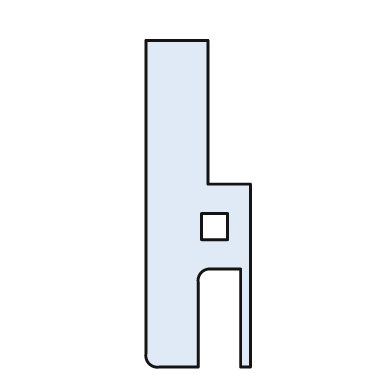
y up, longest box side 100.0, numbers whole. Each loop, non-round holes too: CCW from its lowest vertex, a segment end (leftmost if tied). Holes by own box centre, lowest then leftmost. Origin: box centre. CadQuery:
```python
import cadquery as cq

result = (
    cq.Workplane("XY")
    .moveTo(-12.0, -50.0)
    .lineTo(0.0, -50.0)
    .lineTo(0.0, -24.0)
    .threePointArc((1.0, -21.0), (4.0, -20.0))
    .lineTo(13.0, -20.0)
    .lineTo(13.0, -50.0)
    .lineTo(16.0, -50.0)
    .lineTo(16.0, 6.0)
    .lineTo(3.0, 6.0)
    .lineTo(3.0, 50.0)
    .lineTo(-16.0, 50.0)
    .lineTo(-16.0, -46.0)
    .threePointArc((-15.0, -49.0), (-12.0, -50.0))
    .close()
    .moveTo(1.0, -11.0)
    .lineTo(9.0, -11.0)
    .lineTo(9.0, -3.0)
    .lineTo(1.0, -3.0)
    .close()
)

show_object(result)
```